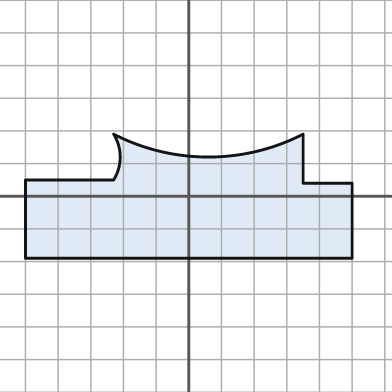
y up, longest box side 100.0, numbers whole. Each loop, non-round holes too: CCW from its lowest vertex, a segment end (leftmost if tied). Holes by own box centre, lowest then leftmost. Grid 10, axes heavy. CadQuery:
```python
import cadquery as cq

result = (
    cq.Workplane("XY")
    .moveTo(-50.0, -19.0)
    .lineTo(50.0, -19.0)
    .lineTo(50.0, 4.0)
    .lineTo(35.0, 4.0)
    .lineTo(35.0, 19.0)
    .threePointArc((6.0, 12.0), (-23.0, 19.0))
    .threePointArc((-21.0, 12.0), (-23.0, 5.0))
    .lineTo(-50.0, 5.0)
    .close()
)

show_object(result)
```